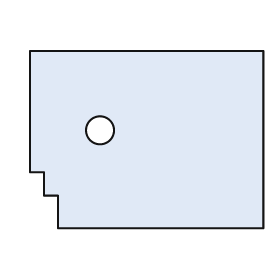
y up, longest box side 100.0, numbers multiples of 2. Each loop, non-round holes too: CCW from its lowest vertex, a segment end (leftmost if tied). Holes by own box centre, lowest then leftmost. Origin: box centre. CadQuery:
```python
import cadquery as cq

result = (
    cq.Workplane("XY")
    .moveTo(-38.0, -38.0)
    .lineTo(50.0, -38.0)
    .lineTo(50.0, 38.0)
    .lineTo(-50.0, 38.0)
    .lineTo(-50.0, -14.0)
    .lineTo(-44.0, -14.0)
    .lineTo(-44.0, -24.0)
    .lineTo(-38.0, -24.0)
    .close()
    .moveTo(-20.0, 4.0)
    .circle(6.0)
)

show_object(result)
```